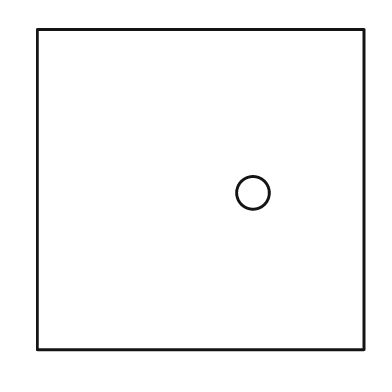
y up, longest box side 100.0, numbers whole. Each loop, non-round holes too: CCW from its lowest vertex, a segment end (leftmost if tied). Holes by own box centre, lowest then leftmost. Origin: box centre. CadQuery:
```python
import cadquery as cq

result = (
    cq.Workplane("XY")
    .moveTo(-50.0, -49.0)
    .lineTo(50.0, -49.0)
    .lineTo(50.0, 49.0)
    .lineTo(-50.0, 49.0)
    .close()
    .moveTo(16.0, -1.0)
    .circle(5.0)
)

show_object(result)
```